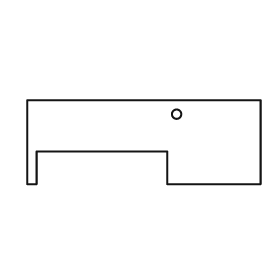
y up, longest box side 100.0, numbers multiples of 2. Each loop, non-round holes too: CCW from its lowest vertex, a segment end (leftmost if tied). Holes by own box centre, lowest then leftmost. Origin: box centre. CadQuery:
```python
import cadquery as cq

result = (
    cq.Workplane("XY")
    .moveTo(-50.0, -18.0)
    .lineTo(-46.0, -18.0)
    .lineTo(-46.0, -4.0)
    .lineTo(10.0, -4.0)
    .lineTo(10.0, -18.0)
    .lineTo(50.0, -18.0)
    .lineTo(50.0, 18.0)
    .lineTo(-50.0, 18.0)
    .close()
    .moveTo(14.0, 12.0)
    .circle(2.0)
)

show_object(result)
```